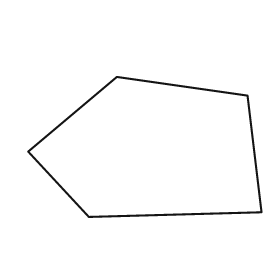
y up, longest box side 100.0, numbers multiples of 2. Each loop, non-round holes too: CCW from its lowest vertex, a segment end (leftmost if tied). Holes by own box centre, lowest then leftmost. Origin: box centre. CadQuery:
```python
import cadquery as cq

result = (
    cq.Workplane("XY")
    .moveTo(-24.0, -30.0)
    .lineTo(50.0, -28.0)
    .lineTo(44.0, 22.0)
    .lineTo(-12.0, 30.0)
    .lineTo(-50.0, -2.0)
    .close()
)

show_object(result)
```